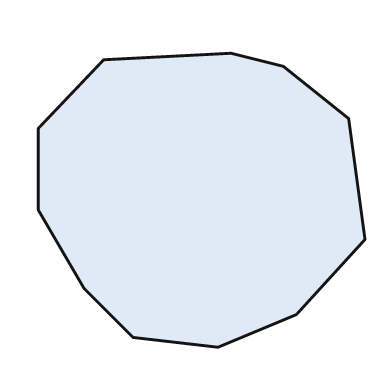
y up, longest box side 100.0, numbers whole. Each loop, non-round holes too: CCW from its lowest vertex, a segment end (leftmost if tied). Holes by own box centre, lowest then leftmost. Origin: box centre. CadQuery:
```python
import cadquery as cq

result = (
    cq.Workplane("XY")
    .moveTo(5.0, -45.0)
    .lineTo(29.0, -35.0)
    .lineTo(50.0, -12.0)
    .lineTo(45.0, 25.0)
    .lineTo(25.0, 41.0)
    .lineTo(9.0, 45.0)
    .lineTo(-30.0, 43.0)
    .lineTo(-50.0, 22.0)
    .lineTo(-50.0, -3.0)
    .lineTo(-36.0, -27.0)
    .lineTo(-21.0, -42.0)
    .close()
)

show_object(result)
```